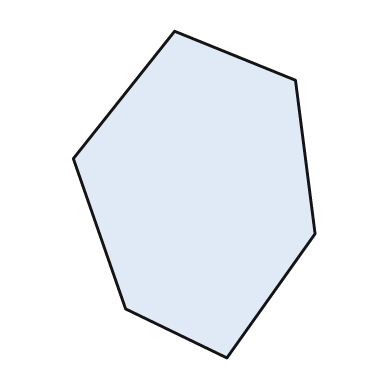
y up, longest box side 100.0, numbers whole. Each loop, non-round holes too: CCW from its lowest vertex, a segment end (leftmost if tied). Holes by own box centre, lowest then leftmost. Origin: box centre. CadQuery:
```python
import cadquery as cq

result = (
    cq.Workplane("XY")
    .moveTo(10.0, -50.0)
    .lineTo(37.0, -12.0)
    .lineTo(31.0, 35.0)
    .lineTo(-6.0, 50.0)
    .lineTo(-37.0, 11.0)
    .lineTo(-21.0, -35.0)
    .close()
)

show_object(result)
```